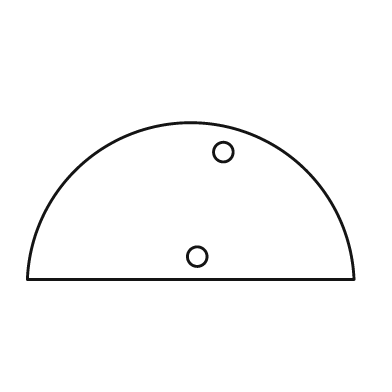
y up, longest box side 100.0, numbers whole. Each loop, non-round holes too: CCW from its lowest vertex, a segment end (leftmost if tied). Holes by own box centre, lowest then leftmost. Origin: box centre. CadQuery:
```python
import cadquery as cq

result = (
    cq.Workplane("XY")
    .moveTo(-50.0, -24.0)
    .lineTo(50.0, -24.0)
    .threePointArc((0.0, 24.0), (-50.0, -24.0))
    .close()
    .moveTo(2.0, -17.0)
    .circle(3.0)
    .moveTo(10.0, 15.0)
    .circle(3.0)
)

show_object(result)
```